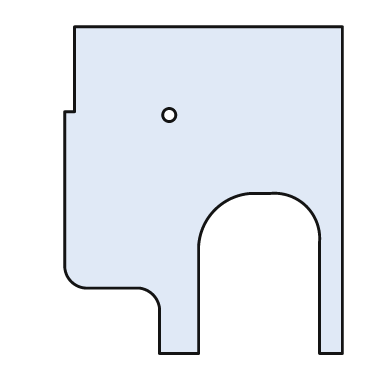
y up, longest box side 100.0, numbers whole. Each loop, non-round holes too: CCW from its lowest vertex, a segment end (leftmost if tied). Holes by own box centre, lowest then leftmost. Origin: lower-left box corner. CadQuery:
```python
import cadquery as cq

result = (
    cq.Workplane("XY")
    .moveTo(29.0, 0.0)
    .lineTo(41.0, 0.0)
    .lineTo(41.0, 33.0)
    .threePointArc((46.0, 44.0), (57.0, 49.0))
    .lineTo(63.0, 49.0)
    .threePointArc((74.0, 45.0), (78.0, 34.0))
    .lineTo(78.0, 0.0)
    .lineTo(85.0, 0.0)
    .lineTo(85.0, 100.0)
    .lineTo(3.0, 100.0)
    .lineTo(3.0, 74.0)
    .lineTo(0.0, 74.0)
    .lineTo(0.0, 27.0)
    .threePointArc((2.0, 22.0), (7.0, 20.0))
    .lineTo(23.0, 20.0)
    .threePointArc((27.0, 18.0), (29.0, 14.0))
    .close()
    .moveTo(32.0, 73.0)
    .circle(2.0)
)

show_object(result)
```